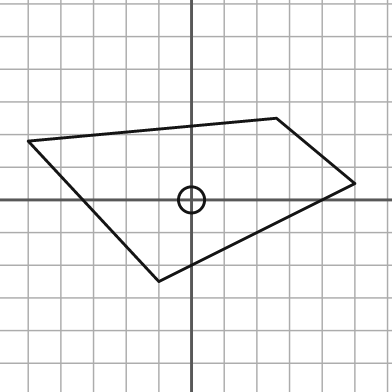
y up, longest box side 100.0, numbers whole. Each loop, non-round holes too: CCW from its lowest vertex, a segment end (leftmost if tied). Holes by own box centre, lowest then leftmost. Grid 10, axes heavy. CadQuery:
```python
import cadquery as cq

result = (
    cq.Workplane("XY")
    .moveTo(-10.0, -25.0)
    .lineTo(50.0, 5.0)
    .lineTo(26.0, 25.0)
    .lineTo(-50.0, 18.0)
    .close()
    .moveTo(0.0, 0.0)
    .circle(4.0)
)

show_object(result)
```